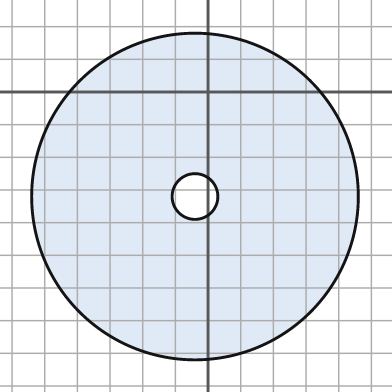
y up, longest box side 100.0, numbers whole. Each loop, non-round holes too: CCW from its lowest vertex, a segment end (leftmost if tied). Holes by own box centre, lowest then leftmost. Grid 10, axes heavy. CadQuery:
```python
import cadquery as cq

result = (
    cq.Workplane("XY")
    .moveTo(-4.0, -32.0)
    .circle(50.0)
    .moveTo(-4.0, -32.0)
    .circle(7.0)
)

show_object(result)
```